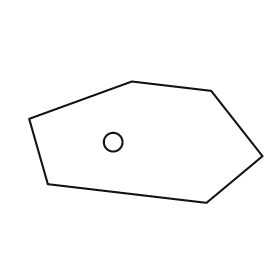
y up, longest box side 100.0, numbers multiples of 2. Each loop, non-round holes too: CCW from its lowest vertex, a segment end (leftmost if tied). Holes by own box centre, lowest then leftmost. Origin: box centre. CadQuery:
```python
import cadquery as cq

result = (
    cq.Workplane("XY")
    .moveTo(26.0, -26.0)
    .lineTo(50.0, -6.0)
    .lineTo(28.0, 22.0)
    .lineTo(-6.0, 26.0)
    .lineTo(-50.0, 10.0)
    .lineTo(-42.0, -18.0)
    .close()
    .moveTo(-14.0, 0.0)
    .circle(4.0)
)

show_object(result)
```